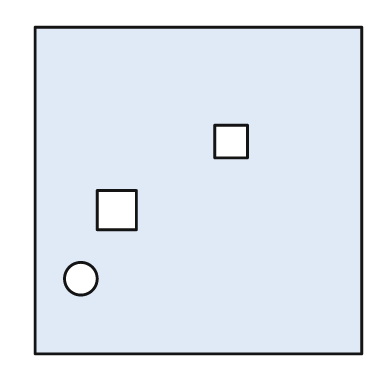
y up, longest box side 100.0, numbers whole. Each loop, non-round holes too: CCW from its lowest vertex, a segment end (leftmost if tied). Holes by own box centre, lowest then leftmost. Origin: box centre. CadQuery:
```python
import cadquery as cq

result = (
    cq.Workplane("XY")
    .moveTo(-50.0, -50.0)
    .lineTo(50.0, -50.0)
    .lineTo(50.0, 50.0)
    .lineTo(-50.0, 50.0)
    .close()
    .moveTo(-36.0, -27.0)
    .circle(5.0)
    .moveTo(-31.0, -12.0)
    .lineTo(-19.0, -12.0)
    .lineTo(-19.0, 0.0)
    .lineTo(-31.0, 0.0)
    .close()
    .moveTo(5.0, 10.0)
    .lineTo(15.0, 10.0)
    .lineTo(15.0, 20.0)
    .lineTo(5.0, 20.0)
    .close()
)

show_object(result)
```